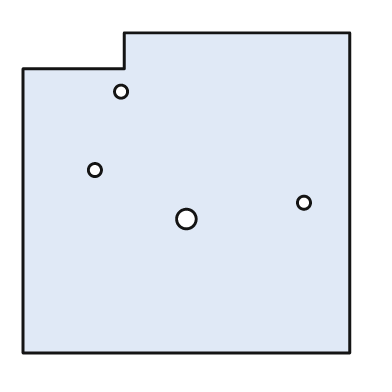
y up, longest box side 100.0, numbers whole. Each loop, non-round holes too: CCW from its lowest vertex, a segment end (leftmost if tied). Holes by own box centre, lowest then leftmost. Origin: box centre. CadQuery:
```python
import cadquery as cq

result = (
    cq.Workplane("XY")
    .moveTo(-50.0, -49.0)
    .lineTo(50.0, -49.0)
    .lineTo(50.0, 49.0)
    .lineTo(-19.0, 49.0)
    .lineTo(-19.0, 38.0)
    .lineTo(-50.0, 38.0)
    .close()
    .moveTo(0.0, -8.0)
    .circle(3.0)
    .moveTo(36.0, -3.0)
    .circle(2.0)
    .moveTo(-28.0, 7.0)
    .circle(2.0)
    .moveTo(-20.0, 31.0)
    .circle(2.0)
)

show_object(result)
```